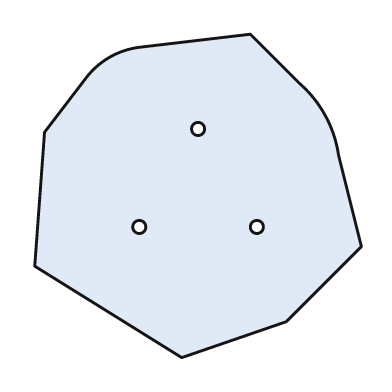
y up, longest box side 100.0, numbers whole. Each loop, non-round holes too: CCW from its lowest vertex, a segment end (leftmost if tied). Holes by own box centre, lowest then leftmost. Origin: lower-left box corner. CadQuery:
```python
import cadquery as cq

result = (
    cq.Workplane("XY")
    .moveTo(45.0, 0.0)
    .lineTo(77.0, 11.0)
    .lineTo(100.0, 34.0)
    .lineTo(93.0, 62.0)
    .threePointArc((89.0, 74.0), (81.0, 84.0))
    .lineTo(66.0, 99.0)
    .lineTo(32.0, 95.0)
    .threePointArc((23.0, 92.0), (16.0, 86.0))
    .lineTo(3.0, 69.0)
    .lineTo(0.0, 28.0)
    .close()
    .moveTo(32.0, 40.0)
    .circle(2.0)
    .moveTo(68.0, 40.0)
    .circle(2.0)
    .moveTo(50.0, 70.0)
    .circle(2.0)
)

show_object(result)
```